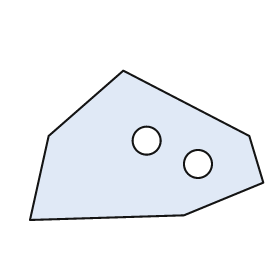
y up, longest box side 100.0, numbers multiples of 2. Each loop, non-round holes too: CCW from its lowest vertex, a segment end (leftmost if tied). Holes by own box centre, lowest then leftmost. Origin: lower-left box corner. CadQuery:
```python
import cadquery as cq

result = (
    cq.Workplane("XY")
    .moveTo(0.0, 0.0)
    .lineTo(66.0, 2.0)
    .lineTo(100.0, 16.0)
    .lineTo(94.0, 36.0)
    .lineTo(40.0, 64.0)
    .lineTo(8.0, 36.0)
    .close()
    .moveTo(72.0, 24.0)
    .circle(6.0)
    .moveTo(50.0, 34.0)
    .circle(6.0)
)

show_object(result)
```